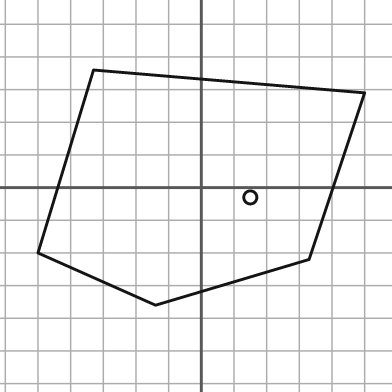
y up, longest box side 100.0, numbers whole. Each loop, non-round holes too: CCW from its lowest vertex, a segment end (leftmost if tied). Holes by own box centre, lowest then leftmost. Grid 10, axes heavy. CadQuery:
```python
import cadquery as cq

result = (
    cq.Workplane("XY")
    .moveTo(-14.0, -36.0)
    .lineTo(33.0, -22.0)
    .lineTo(50.0, 29.0)
    .lineTo(-33.0, 36.0)
    .lineTo(-50.0, -20.0)
    .close()
    .moveTo(15.0, -3.0)
    .circle(2.0)
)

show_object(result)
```